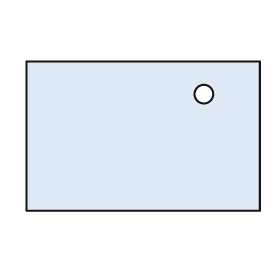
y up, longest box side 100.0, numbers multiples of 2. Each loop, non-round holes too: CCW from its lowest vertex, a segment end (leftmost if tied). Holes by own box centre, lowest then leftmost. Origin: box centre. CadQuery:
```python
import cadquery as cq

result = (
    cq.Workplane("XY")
    .moveTo(-50.0, -32.0)
    .lineTo(50.0, -32.0)
    .lineTo(50.0, 32.0)
    .lineTo(-50.0, 32.0)
    .close()
    .moveTo(26.0, 18.0)
    .circle(4.0)
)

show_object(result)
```